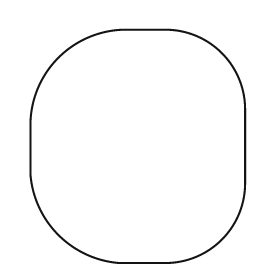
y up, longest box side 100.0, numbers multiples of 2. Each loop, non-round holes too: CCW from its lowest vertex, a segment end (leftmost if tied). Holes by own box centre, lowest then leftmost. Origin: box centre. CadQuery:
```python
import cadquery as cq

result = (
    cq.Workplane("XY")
    .moveTo(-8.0, -50.0)
    .lineTo(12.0, -50.0)
    .threePointArc((36.0, -40.0), (46.0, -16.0))
    .lineTo(46.0, 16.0)
    .threePointArc((36.0, 40.0), (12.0, 50.0))
    .lineTo(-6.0, 50.0)
    .threePointArc((-34.0, 38.0), (-46.0, 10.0))
    .lineTo(-46.0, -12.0)
    .threePointArc((-34.0, -38.0), (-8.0, -50.0))
    .close()
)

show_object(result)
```